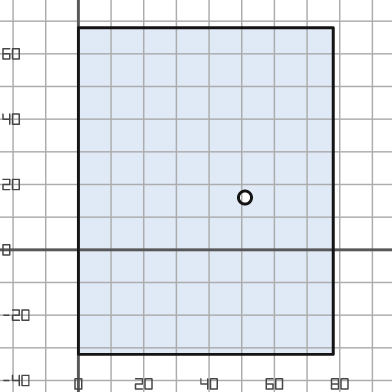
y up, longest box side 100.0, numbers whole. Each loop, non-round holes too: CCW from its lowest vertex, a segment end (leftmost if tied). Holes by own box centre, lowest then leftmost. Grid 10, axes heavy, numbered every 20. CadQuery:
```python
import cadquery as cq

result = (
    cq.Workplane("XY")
    .moveTo(0.0, -32.0)
    .lineTo(78.0, -32.0)
    .lineTo(78.0, 68.0)
    .lineTo(0.0, 68.0)
    .close()
    .moveTo(51.0, 16.0)
    .circle(2.0)
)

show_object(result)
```